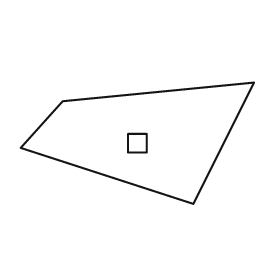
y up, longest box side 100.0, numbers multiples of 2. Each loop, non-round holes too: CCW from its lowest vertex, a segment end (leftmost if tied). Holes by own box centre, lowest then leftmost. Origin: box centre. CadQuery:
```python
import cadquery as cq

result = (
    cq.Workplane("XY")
    .moveTo(24.0, -26.0)
    .lineTo(50.0, 26.0)
    .lineTo(-32.0, 18.0)
    .lineTo(-50.0, -2.0)
    .close()
    .moveTo(-4.0, -4.0)
    .lineTo(4.0, -4.0)
    .lineTo(4.0, 4.0)
    .lineTo(-4.0, 4.0)
    .close()
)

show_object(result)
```